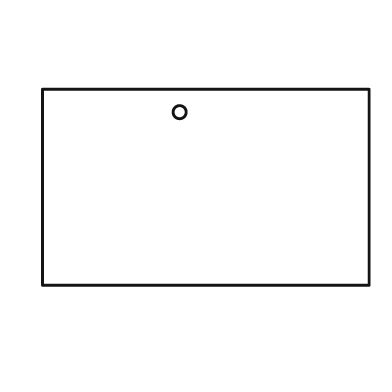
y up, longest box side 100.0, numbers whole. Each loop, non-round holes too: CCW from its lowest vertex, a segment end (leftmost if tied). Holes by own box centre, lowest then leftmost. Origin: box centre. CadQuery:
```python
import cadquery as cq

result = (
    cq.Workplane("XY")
    .moveTo(-50.0, -30.0)
    .lineTo(50.0, -30.0)
    .lineTo(50.0, 30.0)
    .lineTo(-50.0, 30.0)
    .close()
    .moveTo(-8.0, 23.0)
    .circle(2.0)
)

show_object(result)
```